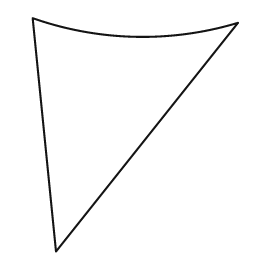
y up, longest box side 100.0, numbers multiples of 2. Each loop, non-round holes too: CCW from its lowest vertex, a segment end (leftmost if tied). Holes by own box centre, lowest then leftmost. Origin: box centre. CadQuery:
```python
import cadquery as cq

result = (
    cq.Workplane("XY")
    .moveTo(-34.0, -50.0)
    .lineTo(44.0, 48.0)
    .threePointArc((0.0, 42.0), (-44.0, 50.0))
    .close()
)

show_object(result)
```